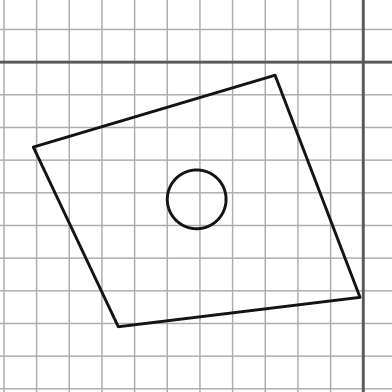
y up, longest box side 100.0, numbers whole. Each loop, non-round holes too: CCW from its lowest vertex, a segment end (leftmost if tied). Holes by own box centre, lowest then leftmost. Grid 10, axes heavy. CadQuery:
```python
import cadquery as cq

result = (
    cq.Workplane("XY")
    .moveTo(-75.0, -81.0)
    .lineTo(-1.0, -72.0)
    .lineTo(-27.0, -4.0)
    .lineTo(-101.0, -26.0)
    .close()
    .moveTo(-51.0, -42.0)
    .circle(9.0)
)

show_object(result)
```